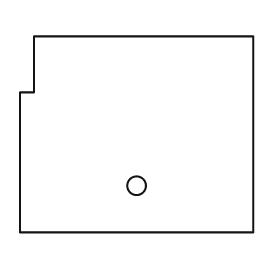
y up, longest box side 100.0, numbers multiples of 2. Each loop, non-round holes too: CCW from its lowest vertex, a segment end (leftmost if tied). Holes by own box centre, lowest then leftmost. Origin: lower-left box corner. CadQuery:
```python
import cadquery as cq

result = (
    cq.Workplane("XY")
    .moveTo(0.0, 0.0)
    .lineTo(100.0, 0.0)
    .lineTo(100.0, 84.0)
    .lineTo(6.0, 84.0)
    .lineTo(6.0, 60.0)
    .lineTo(0.0, 60.0)
    .close()
    .moveTo(50.0, 20.0)
    .circle(4.0)
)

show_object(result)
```